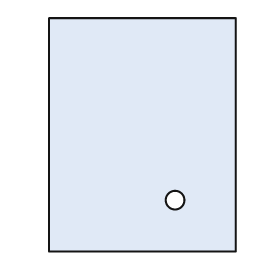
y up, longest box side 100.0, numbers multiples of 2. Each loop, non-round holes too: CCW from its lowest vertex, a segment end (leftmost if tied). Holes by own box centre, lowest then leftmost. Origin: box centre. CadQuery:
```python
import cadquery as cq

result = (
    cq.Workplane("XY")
    .moveTo(-40.0, -50.0)
    .lineTo(40.0, -50.0)
    .lineTo(40.0, 50.0)
    .lineTo(-40.0, 50.0)
    .close()
    .moveTo(14.0, -28.0)
    .circle(4.0)
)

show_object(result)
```